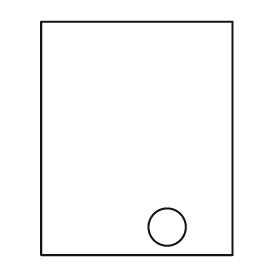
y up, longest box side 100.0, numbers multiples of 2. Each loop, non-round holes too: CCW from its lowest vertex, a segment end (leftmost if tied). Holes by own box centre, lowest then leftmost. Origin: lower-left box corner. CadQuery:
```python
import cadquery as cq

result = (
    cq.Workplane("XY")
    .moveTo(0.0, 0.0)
    .lineTo(82.0, 0.0)
    .lineTo(82.0, 100.0)
    .lineTo(0.0, 100.0)
    .close()
    .moveTo(54.0, 12.0)
    .circle(8.0)
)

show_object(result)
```